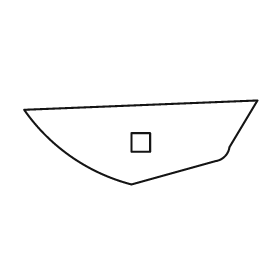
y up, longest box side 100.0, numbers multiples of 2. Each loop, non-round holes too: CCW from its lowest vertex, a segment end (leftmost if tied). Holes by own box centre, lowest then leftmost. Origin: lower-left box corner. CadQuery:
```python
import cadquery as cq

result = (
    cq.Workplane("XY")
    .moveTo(46.0, 0.0)
    .lineTo(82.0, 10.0)
    .threePointArc((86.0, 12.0), (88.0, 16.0))
    .lineTo(100.0, 36.0)
    .lineTo(0.0, 32.0)
    .threePointArc((20.0, 12.0), (46.0, 0.0))
    .close()
    .moveTo(46.0, 14.0)
    .lineTo(54.0, 14.0)
    .lineTo(54.0, 22.0)
    .lineTo(46.0, 22.0)
    .close()
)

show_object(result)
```